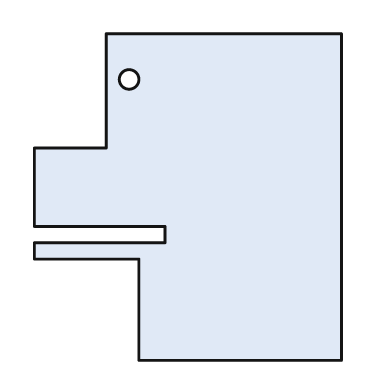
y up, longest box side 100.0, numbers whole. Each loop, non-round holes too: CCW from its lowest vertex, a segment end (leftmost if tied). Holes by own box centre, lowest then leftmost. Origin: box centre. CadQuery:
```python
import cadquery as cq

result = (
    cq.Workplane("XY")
    .moveTo(-15.0, -50.0)
    .lineTo(47.0, -50.0)
    .lineTo(47.0, 50.0)
    .lineTo(-25.0, 50.0)
    .lineTo(-25.0, 15.0)
    .lineTo(-47.0, 15.0)
    .lineTo(-47.0, -9.0)
    .lineTo(-7.0, -9.0)
    .lineTo(-7.0, -14.0)
    .lineTo(-47.0, -14.0)
    .lineTo(-47.0, -19.0)
    .lineTo(-15.0, -19.0)
    .close()
    .moveTo(-18.0, 36.0)
    .circle(3.0)
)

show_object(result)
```